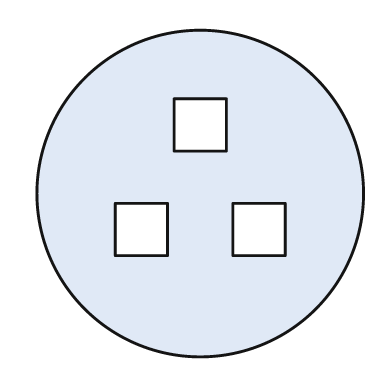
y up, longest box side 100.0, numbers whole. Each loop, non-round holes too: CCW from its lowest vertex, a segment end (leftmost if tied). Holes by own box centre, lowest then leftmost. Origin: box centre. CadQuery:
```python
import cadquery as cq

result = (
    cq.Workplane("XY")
    .moveTo(0.0, 0.0)
    .circle(50.0)
    .moveTo(-26.0, -19.0)
    .lineTo(-10.0, -19.0)
    .lineTo(-10.0, -3.0)
    .lineTo(-26.0, -3.0)
    .close()
    .moveTo(10.0, -19.0)
    .lineTo(26.0, -19.0)
    .lineTo(26.0, -3.0)
    .lineTo(10.0, -3.0)
    .close()
    .moveTo(-8.0, 13.0)
    .lineTo(8.0, 13.0)
    .lineTo(8.0, 29.0)
    .lineTo(-8.0, 29.0)
    .close()
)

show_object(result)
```